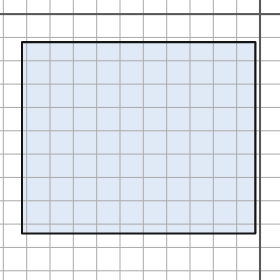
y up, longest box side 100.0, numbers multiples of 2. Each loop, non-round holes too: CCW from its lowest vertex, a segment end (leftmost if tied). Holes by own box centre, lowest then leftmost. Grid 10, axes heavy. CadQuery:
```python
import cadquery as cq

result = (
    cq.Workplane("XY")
    .moveTo(-102.0, -94.0)
    .lineTo(-2.0, -94.0)
    .lineTo(-2.0, -12.0)
    .lineTo(-102.0, -12.0)
    .close()
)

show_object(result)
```